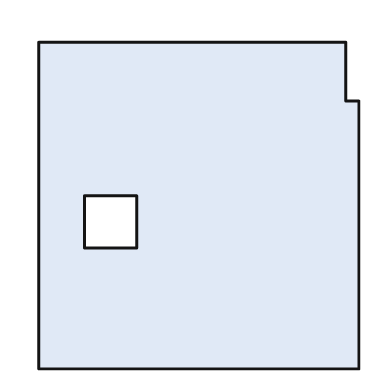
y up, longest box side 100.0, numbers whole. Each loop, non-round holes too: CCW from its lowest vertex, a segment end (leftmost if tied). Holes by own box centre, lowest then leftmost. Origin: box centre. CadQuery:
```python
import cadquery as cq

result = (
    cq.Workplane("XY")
    .moveTo(-49.0, -50.0)
    .lineTo(49.0, -50.0)
    .lineTo(49.0, 32.0)
    .lineTo(45.0, 32.0)
    .lineTo(45.0, 50.0)
    .lineTo(-49.0, 50.0)
    .close()
    .moveTo(-35.0, -13.0)
    .lineTo(-19.0, -13.0)
    .lineTo(-19.0, 3.0)
    .lineTo(-35.0, 3.0)
    .close()
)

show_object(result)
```